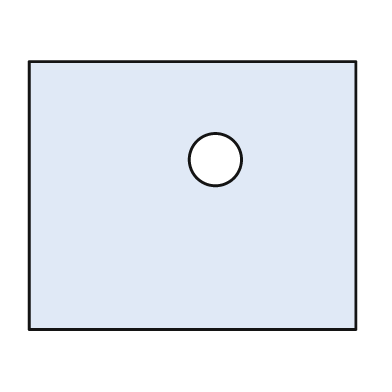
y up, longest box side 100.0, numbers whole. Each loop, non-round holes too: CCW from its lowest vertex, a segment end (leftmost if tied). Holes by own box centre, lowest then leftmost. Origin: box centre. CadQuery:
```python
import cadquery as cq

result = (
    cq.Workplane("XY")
    .moveTo(-50.0, -41.0)
    .lineTo(50.0, -41.0)
    .lineTo(50.0, 41.0)
    .lineTo(-50.0, 41.0)
    .close()
    .moveTo(7.0, 11.0)
    .circle(8.0)
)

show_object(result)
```